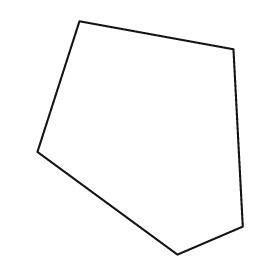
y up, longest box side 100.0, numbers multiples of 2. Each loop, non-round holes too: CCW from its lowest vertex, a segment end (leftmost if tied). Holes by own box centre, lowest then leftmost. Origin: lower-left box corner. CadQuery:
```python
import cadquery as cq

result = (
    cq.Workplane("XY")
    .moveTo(60.0, 0.0)
    .lineTo(88.0, 12.0)
    .lineTo(84.0, 88.0)
    .lineTo(18.0, 100.0)
    .lineTo(0.0, 44.0)
    .close()
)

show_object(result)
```